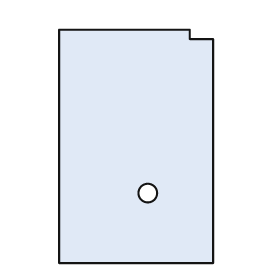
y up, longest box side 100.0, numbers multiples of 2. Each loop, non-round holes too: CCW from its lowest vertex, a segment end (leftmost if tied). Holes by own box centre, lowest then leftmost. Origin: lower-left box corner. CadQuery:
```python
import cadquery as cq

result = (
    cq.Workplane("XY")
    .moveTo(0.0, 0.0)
    .lineTo(66.0, 0.0)
    .lineTo(66.0, 96.0)
    .lineTo(56.0, 96.0)
    .lineTo(56.0, 100.0)
    .lineTo(0.0, 100.0)
    .close()
    .moveTo(38.0, 30.0)
    .circle(4.0)
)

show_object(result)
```